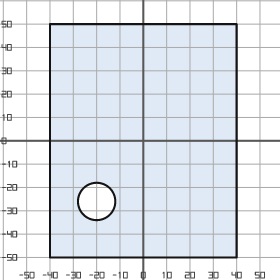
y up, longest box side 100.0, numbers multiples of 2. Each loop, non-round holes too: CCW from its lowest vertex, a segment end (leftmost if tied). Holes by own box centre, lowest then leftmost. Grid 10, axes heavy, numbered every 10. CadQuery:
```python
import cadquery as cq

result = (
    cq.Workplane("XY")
    .moveTo(-40.0, -50.0)
    .lineTo(40.0, -50.0)
    .lineTo(40.0, 50.0)
    .lineTo(-40.0, 50.0)
    .close()
    .moveTo(-20.0, -26.0)
    .circle(8.0)
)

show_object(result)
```